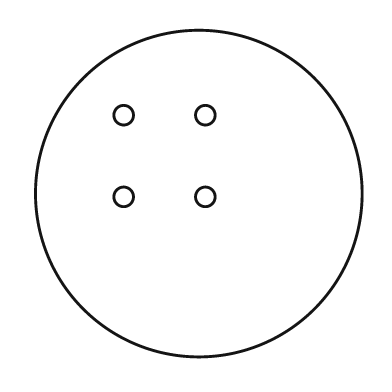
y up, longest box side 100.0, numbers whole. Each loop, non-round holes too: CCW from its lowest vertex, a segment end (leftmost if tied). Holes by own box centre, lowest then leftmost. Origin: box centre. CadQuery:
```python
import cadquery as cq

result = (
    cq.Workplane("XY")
    .moveTo(0.0, 0.0)
    .circle(50.0)
    .moveTo(-23.0, -1.0)
    .circle(3.0)
    .moveTo(2.0, -1.0)
    .circle(3.0)
    .moveTo(-23.0, 24.0)
    .circle(3.0)
    .moveTo(2.0, 24.0)
    .circle(3.0)
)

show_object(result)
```